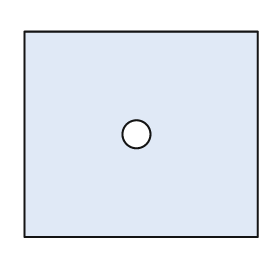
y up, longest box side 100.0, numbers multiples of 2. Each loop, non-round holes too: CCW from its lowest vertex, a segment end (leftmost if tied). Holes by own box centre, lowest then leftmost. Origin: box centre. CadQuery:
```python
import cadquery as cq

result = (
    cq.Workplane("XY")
    .moveTo(-50.0, -44.0)
    .lineTo(50.0, -44.0)
    .lineTo(50.0, 44.0)
    .lineTo(-50.0, 44.0)
    .close()
    .moveTo(-2.0, 0.0)
    .circle(6.0)
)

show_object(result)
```